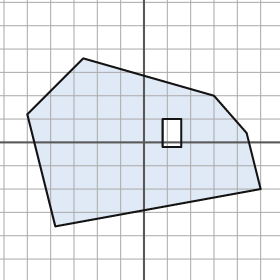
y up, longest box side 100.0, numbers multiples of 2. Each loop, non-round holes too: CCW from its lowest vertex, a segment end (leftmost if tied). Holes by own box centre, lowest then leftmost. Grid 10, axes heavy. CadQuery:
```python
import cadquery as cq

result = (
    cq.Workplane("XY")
    .moveTo(-38.0, -36.0)
    .lineTo(50.0, -20.0)
    .lineTo(44.0, 4.0)
    .lineTo(30.0, 20.0)
    .lineTo(-26.0, 36.0)
    .lineTo(-50.0, 12.0)
    .close()
    .moveTo(8.0, -2.0)
    .lineTo(16.0, -2.0)
    .lineTo(16.0, 10.0)
    .lineTo(8.0, 10.0)
    .close()
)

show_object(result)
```